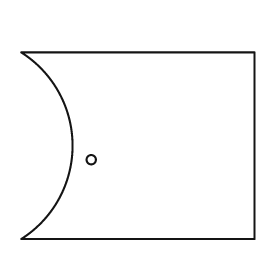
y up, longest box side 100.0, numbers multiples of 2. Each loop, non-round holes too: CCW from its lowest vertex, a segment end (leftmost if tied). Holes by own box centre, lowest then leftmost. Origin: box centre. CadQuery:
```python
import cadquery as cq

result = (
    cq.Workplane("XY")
    .moveTo(-50.0, -40.0)
    .lineTo(50.0, -40.0)
    .lineTo(50.0, 40.0)
    .lineTo(-50.0, 40.0)
    .threePointArc((-28.0, 0.0), (-50.0, -40.0))
    .close()
    .moveTo(-20.0, -6.0)
    .circle(2.0)
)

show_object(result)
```